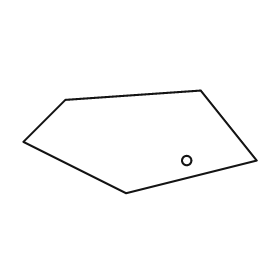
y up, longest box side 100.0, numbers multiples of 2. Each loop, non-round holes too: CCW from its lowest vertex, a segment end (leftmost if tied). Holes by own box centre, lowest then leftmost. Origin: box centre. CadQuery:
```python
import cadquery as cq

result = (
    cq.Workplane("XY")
    .moveTo(-6.0, -22.0)
    .lineTo(50.0, -8.0)
    .lineTo(26.0, 22.0)
    .lineTo(-32.0, 18.0)
    .lineTo(-50.0, 0.0)
    .close()
    .moveTo(20.0, -8.0)
    .circle(2.0)
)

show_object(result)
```